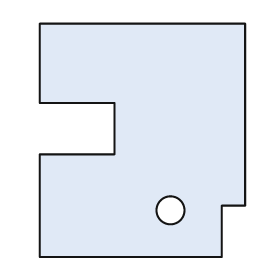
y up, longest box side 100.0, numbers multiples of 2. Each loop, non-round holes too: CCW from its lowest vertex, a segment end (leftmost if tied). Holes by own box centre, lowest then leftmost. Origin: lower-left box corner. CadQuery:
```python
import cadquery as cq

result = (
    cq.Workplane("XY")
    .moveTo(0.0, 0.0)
    .lineTo(78.0, 0.0)
    .lineTo(78.0, 22.0)
    .lineTo(88.0, 22.0)
    .lineTo(88.0, 100.0)
    .lineTo(0.0, 100.0)
    .lineTo(0.0, 66.0)
    .lineTo(32.0, 66.0)
    .lineTo(32.0, 44.0)
    .lineTo(0.0, 44.0)
    .close()
    .moveTo(56.0, 20.0)
    .circle(6.0)
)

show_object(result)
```